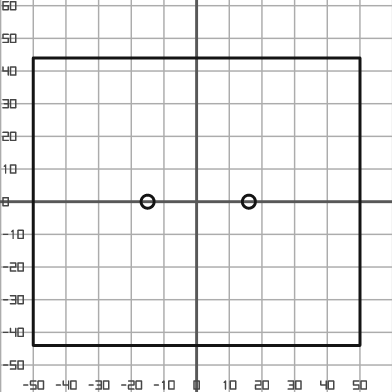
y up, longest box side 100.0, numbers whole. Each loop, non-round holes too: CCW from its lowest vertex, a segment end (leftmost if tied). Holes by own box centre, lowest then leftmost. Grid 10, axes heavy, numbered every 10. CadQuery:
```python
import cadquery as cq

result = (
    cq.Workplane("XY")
    .moveTo(-50.0, -44.0)
    .lineTo(50.0, -44.0)
    .lineTo(50.0, 44.0)
    .lineTo(-50.0, 44.0)
    .close()
    .moveTo(-15.0, 0.0)
    .circle(2.0)
    .moveTo(16.0, 0.0)
    .circle(2.0)
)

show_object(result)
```